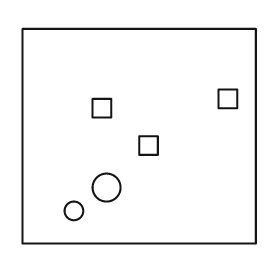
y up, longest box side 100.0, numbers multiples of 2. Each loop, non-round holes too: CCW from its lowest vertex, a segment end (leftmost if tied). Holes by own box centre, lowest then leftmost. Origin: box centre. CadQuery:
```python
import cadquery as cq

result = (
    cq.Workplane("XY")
    .moveTo(-50.0, -46.0)
    .lineTo(50.0, -46.0)
    .lineTo(50.0, 46.0)
    .lineTo(-50.0, 46.0)
    .close()
    .moveTo(-28.0, -32.0)
    .circle(4.0)
    .moveTo(-14.0, -22.0)
    .circle(6.0)
    .moveTo(0.0, -8.0)
    .lineTo(8.0, -8.0)
    .lineTo(8.0, 0.0)
    .lineTo(0.0, 0.0)
    .close()
    .moveTo(-20.0, 8.0)
    .lineTo(-12.0, 8.0)
    .lineTo(-12.0, 16.0)
    .lineTo(-20.0, 16.0)
    .close()
    .moveTo(34.0, 12.0)
    .lineTo(42.0, 12.0)
    .lineTo(42.0, 20.0)
    .lineTo(34.0, 20.0)
    .close()
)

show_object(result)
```